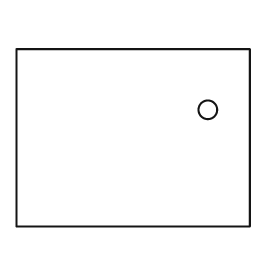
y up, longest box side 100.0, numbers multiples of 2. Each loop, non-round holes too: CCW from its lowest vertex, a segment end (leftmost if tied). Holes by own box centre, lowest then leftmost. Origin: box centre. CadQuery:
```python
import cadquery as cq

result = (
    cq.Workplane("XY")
    .moveTo(-50.0, -38.0)
    .lineTo(50.0, -38.0)
    .lineTo(50.0, 38.0)
    .lineTo(-50.0, 38.0)
    .close()
    .moveTo(32.0, 12.0)
    .circle(4.0)
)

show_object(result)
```